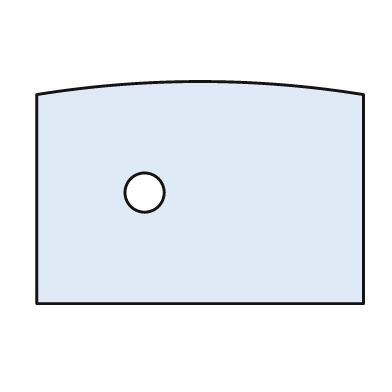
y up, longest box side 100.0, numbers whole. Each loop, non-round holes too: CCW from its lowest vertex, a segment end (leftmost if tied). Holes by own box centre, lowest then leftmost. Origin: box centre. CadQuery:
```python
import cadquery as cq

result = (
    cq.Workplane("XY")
    .moveTo(-50.0, -34.0)
    .lineTo(50.0, -34.0)
    .lineTo(50.0, 30.0)
    .threePointArc((0.0, 34.0), (-50.0, 30.0))
    .close()
    .moveTo(-17.0, 0.0)
    .circle(6.0)
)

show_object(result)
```